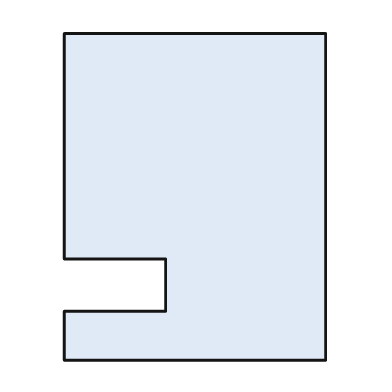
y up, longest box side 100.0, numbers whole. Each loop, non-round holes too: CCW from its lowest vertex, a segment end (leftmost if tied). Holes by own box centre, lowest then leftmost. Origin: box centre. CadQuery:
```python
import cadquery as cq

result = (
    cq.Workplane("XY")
    .moveTo(-40.0, -50.0)
    .lineTo(40.0, -50.0)
    .lineTo(40.0, 50.0)
    .lineTo(-40.0, 50.0)
    .lineTo(-40.0, -19.0)
    .lineTo(-9.0, -19.0)
    .lineTo(-9.0, -35.0)
    .lineTo(-40.0, -35.0)
    .close()
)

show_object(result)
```